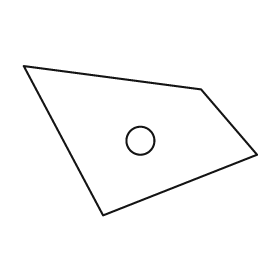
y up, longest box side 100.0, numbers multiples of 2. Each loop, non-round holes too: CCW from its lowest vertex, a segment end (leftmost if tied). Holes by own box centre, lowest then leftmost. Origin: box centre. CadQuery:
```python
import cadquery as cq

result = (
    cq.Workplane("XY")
    .moveTo(-16.0, -32.0)
    .lineTo(50.0, -6.0)
    .lineTo(26.0, 22.0)
    .lineTo(-50.0, 32.0)
    .close()
    .moveTo(0.0, 0.0)
    .circle(6.0)
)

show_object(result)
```